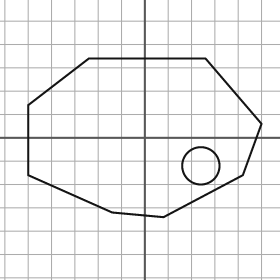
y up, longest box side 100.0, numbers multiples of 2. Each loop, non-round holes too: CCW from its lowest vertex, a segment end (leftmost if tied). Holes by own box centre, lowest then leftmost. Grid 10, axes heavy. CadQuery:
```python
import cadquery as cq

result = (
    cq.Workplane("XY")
    .moveTo(8.0, -34.0)
    .lineTo(42.0, -16.0)
    .lineTo(50.0, 6.0)
    .lineTo(26.0, 34.0)
    .lineTo(-24.0, 34.0)
    .lineTo(-50.0, 14.0)
    .lineTo(-50.0, -16.0)
    .lineTo(-14.0, -32.0)
    .close()
    .moveTo(24.0, -12.0)
    .circle(8.0)
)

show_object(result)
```